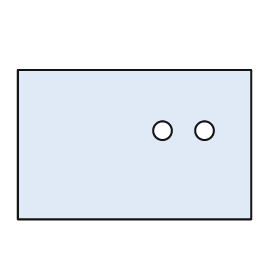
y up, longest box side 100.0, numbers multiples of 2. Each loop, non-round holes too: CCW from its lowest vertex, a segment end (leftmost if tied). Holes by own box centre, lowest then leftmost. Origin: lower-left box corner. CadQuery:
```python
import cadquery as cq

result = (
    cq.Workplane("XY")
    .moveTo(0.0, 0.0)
    .lineTo(100.0, 0.0)
    .lineTo(100.0, 64.0)
    .lineTo(0.0, 64.0)
    .close()
    .moveTo(62.0, 38.0)
    .circle(4.0)
    .moveTo(80.0, 38.0)
    .circle(4.0)
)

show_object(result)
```